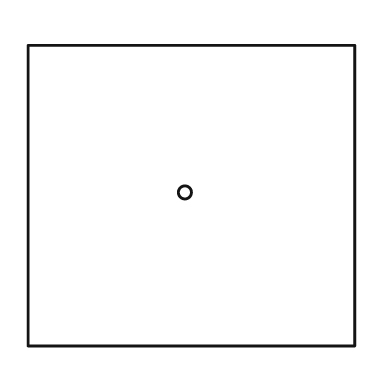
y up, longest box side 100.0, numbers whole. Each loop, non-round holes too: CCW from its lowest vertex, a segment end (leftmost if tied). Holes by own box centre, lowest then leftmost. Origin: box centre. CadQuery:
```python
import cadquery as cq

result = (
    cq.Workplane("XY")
    .moveTo(-50.0, -46.0)
    .lineTo(50.0, -46.0)
    .lineTo(50.0, 46.0)
    .lineTo(-50.0, 46.0)
    .close()
    .moveTo(-2.0, 1.0)
    .circle(2.0)
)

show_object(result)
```